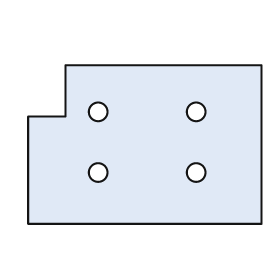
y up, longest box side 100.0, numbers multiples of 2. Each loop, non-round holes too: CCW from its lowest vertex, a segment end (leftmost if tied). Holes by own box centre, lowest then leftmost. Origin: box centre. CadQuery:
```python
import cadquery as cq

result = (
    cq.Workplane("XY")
    .moveTo(-50.0, -34.0)
    .lineTo(50.0, -34.0)
    .lineTo(50.0, 34.0)
    .lineTo(-34.0, 34.0)
    .lineTo(-34.0, 12.0)
    .lineTo(-50.0, 12.0)
    .close()
    .moveTo(-20.0, -12.0)
    .circle(4.0)
    .moveTo(22.0, -12.0)
    .circle(4.0)
    .moveTo(-20.0, 14.0)
    .circle(4.0)
    .moveTo(22.0, 14.0)
    .circle(4.0)
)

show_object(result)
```